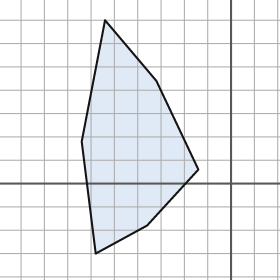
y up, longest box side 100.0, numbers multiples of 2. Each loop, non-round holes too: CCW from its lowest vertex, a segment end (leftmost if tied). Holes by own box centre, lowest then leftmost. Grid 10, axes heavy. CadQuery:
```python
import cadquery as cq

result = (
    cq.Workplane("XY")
    .moveTo(-58.0, -30.0)
    .lineTo(-36.0, -18.0)
    .lineTo(-14.0, 6.0)
    .lineTo(-32.0, 44.0)
    .lineTo(-54.0, 70.0)
    .lineTo(-64.0, 18.0)
    .close()
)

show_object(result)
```